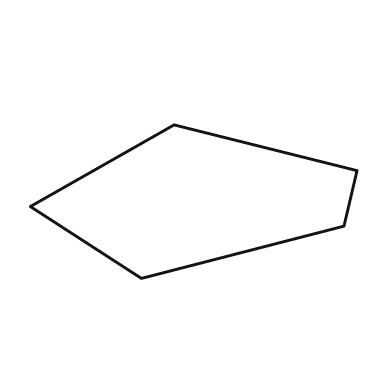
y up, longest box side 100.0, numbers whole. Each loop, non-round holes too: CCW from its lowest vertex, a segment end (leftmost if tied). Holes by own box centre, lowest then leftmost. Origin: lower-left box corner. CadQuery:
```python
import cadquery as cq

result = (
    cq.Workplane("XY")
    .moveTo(34.0, 0.0)
    .lineTo(96.0, 16.0)
    .lineTo(100.0, 33.0)
    .lineTo(44.0, 47.0)
    .lineTo(0.0, 22.0)
    .close()
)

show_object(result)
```